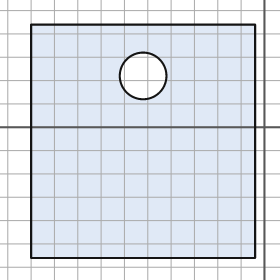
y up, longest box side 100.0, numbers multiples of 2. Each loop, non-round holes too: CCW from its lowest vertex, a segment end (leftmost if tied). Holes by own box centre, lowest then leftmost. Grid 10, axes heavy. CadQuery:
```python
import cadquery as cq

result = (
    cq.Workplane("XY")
    .moveTo(-100.0, -56.0)
    .lineTo(-4.0, -56.0)
    .lineTo(-4.0, 44.0)
    .lineTo(-100.0, 44.0)
    .close()
    .moveTo(-52.0, 22.0)
    .circle(10.0)
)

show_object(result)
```